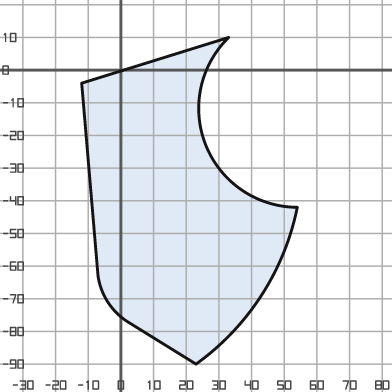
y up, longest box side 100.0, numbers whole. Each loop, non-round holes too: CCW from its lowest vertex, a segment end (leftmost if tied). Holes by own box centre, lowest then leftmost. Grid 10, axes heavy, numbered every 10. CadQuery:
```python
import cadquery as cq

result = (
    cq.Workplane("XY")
    .moveTo(23.0, -90.0)
    .threePointArc((43.0, -69.0), (54.0, -42.0))
    .threePointArc((26.0, -23.0), (33.0, 10.0))
    .lineTo(-12.0, -4.0)
    .lineTo(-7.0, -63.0)
    .threePointArc((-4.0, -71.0), (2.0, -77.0))
    .close()
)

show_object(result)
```